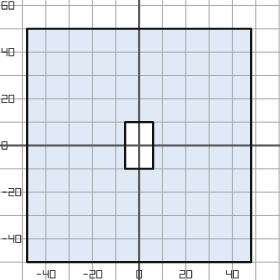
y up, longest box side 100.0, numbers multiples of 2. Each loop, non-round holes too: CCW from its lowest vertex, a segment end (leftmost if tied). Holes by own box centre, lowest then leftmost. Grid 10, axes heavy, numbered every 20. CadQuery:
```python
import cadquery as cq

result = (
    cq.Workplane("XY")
    .moveTo(-48.0, -50.0)
    .lineTo(48.0, -50.0)
    .lineTo(48.0, 50.0)
    .lineTo(-48.0, 50.0)
    .close()
    .moveTo(-6.0, -10.0)
    .lineTo(6.0, -10.0)
    .lineTo(6.0, 10.0)
    .lineTo(-6.0, 10.0)
    .close()
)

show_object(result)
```